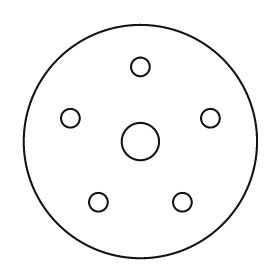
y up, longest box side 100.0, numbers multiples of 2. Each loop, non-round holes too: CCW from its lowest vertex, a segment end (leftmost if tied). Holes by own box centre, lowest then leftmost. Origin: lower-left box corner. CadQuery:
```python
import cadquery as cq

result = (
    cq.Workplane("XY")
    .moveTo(50.0, 50.0)
    .circle(50.0)
    .moveTo(32.0, 24.0)
    .circle(4.0)
    .moveTo(68.0, 24.0)
    .circle(4.0)
    .moveTo(50.0, 50.0)
    .circle(8.0)
    .moveTo(20.0, 60.0)
    .circle(4.0)
    .moveTo(80.0, 60.0)
    .circle(4.0)
    .moveTo(50.0, 82.0)
    .circle(4.0)
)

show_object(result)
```